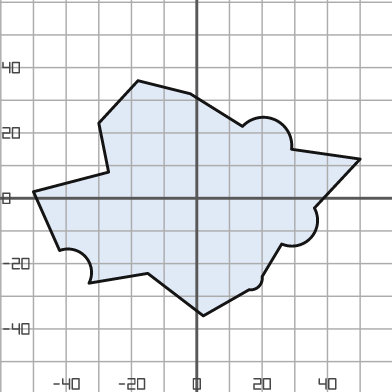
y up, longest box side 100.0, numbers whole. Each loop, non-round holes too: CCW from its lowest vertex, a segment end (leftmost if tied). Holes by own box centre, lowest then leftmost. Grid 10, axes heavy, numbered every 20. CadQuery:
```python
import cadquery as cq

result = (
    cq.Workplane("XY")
    .moveTo(2.0, -36.0)
    .lineTo(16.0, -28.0)
    .threePointArc((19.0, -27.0), (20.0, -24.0))
    .lineTo(26.0, -14.0)
    .threePointArc((35.0, -12.0), (36.0, -3.0))
    .lineTo(50.0, 12.0)
    .lineTo(29.0, 15.0)
    .threePointArc((24.0, 24.0), (14.0, 22.0))
    .lineTo(-2.0, 32.0)
    .lineTo(-18.0, 36.0)
    .lineTo(-30.0, 23.0)
    .lineTo(-27.0, 8.0)
    .lineTo(-50.0, 2.0)
    .lineTo(-42.0, -16.0)
    .threePointArc((-34.0, -18.0), (-33.0, -26.0))
    .lineTo(-15.0, -23.0)
    .close()
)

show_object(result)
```